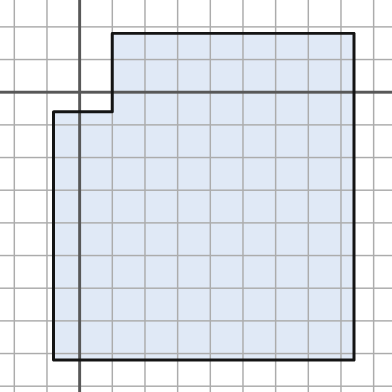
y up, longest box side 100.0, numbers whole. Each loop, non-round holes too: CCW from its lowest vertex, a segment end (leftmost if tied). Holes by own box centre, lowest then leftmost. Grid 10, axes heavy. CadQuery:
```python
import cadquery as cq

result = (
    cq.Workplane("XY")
    .moveTo(-8.0, -82.0)
    .lineTo(84.0, -82.0)
    .lineTo(84.0, 18.0)
    .lineTo(10.0, 18.0)
    .lineTo(10.0, -6.0)
    .lineTo(-8.0, -6.0)
    .close()
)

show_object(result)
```